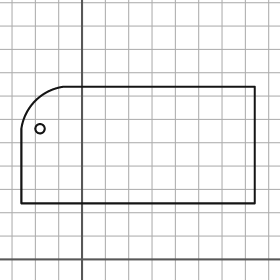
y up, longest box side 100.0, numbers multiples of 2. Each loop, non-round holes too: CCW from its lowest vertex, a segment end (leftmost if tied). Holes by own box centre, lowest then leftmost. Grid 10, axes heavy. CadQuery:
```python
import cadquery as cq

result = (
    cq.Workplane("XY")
    .moveTo(-26.0, 24.0)
    .lineTo(74.0, 24.0)
    .lineTo(74.0, 74.0)
    .lineTo(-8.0, 74.0)
    .threePointArc((-20.0, 68.0), (-26.0, 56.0))
    .close()
    .moveTo(-18.0, 56.0)
    .circle(2.0)
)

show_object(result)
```